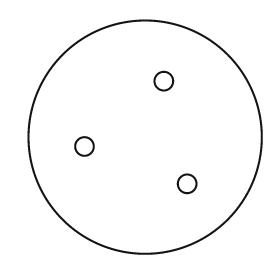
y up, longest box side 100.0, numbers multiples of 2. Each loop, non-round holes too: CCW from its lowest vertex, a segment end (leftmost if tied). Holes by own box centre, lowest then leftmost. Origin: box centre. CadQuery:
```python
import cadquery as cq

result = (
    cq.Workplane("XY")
    .moveTo(0.0, 0.0)
    .circle(50.0)
    .moveTo(18.0, -20.0)
    .circle(4.0)
    .moveTo(-26.0, -4.0)
    .circle(4.0)
    .moveTo(8.0, 24.0)
    .circle(4.0)
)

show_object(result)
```